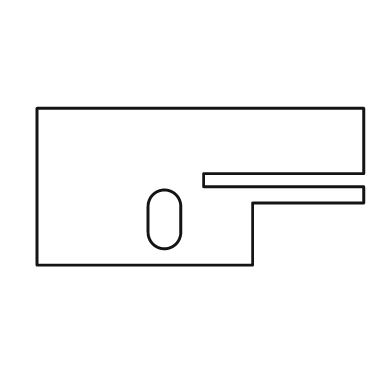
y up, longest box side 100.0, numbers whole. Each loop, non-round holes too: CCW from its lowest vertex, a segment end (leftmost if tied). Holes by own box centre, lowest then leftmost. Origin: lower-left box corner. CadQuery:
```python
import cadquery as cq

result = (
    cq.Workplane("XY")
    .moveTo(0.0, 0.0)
    .lineTo(66.0, 0.0)
    .lineTo(66.0, 19.0)
    .lineTo(100.0, 19.0)
    .lineTo(100.0, 24.0)
    .lineTo(51.0, 24.0)
    .lineTo(51.0, 28.0)
    .lineTo(100.0, 28.0)
    .lineTo(100.0, 48.0)
    .lineTo(0.0, 48.0)
    .close()
    .moveTo(34.0, 10.0)
    .threePointArc((39.0, 5.0), (44.0, 10.0))
    .lineTo(44.0, 18.0)
    .threePointArc((39.0, 23.0), (34.0, 18.0))
    .close()
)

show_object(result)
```